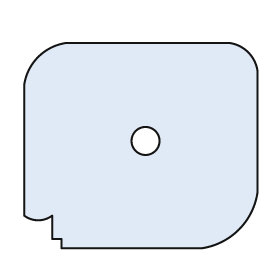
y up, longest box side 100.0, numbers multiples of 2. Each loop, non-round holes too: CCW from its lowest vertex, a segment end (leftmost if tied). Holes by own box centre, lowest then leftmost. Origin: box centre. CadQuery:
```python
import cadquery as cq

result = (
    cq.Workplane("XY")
    .moveTo(-34.0, -44.0)
    .lineTo(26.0, -44.0)
    .threePointArc((42.0, -36.0), (50.0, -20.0))
    .lineTo(50.0, 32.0)
    .threePointArc((46.0, 40.0), (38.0, 44.0))
    .lineTo(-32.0, 44.0)
    .threePointArc((-44.0, 38.0), (-50.0, 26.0))
    .lineTo(-50.0, -30.0)
    .threePointArc((-44.0, -32.0), (-38.0, -30.0))
    .lineTo(-38.0, -40.0)
    .lineTo(-34.0, -40.0)
    .close()
    .moveTo(2.0, 2.0)
    .circle(6.0)
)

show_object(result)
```